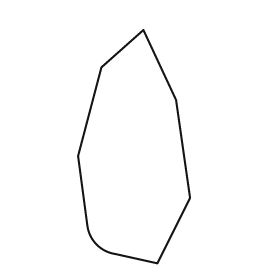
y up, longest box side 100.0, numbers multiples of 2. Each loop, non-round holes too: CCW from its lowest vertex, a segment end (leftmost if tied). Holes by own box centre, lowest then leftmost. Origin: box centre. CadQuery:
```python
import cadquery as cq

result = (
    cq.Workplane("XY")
    .moveTo(10.0, -50.0)
    .lineTo(24.0, -22.0)
    .lineTo(18.0, 20.0)
    .lineTo(4.0, 50.0)
    .lineTo(-14.0, 34.0)
    .lineTo(-24.0, -4.0)
    .lineTo(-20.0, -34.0)
    .threePointArc((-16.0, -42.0), (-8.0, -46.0))
    .close()
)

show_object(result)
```